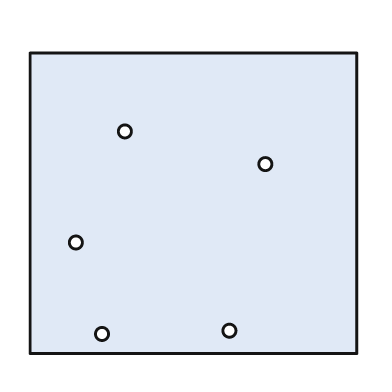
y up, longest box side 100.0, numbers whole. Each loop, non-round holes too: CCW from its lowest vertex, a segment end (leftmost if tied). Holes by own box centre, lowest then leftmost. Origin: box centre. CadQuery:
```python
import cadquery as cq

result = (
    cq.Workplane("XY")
    .moveTo(-50.0, -46.0)
    .lineTo(50.0, -46.0)
    .lineTo(50.0, 46.0)
    .lineTo(-50.0, 46.0)
    .close()
    .moveTo(-28.0, -40.0)
    .circle(2.0)
    .moveTo(11.0, -39.0)
    .circle(2.0)
    .moveTo(-36.0, -12.0)
    .circle(2.0)
    .moveTo(22.0, 12.0)
    .circle(2.0)
    .moveTo(-21.0, 22.0)
    .circle(2.0)
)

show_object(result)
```